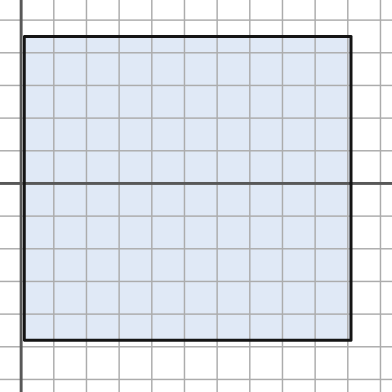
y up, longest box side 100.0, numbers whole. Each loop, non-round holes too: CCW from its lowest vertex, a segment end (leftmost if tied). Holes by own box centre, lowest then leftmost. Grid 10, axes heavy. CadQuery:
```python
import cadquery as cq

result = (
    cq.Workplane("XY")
    .moveTo(1.0, -48.0)
    .lineTo(101.0, -48.0)
    .lineTo(101.0, 45.0)
    .lineTo(1.0, 45.0)
    .close()
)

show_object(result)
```